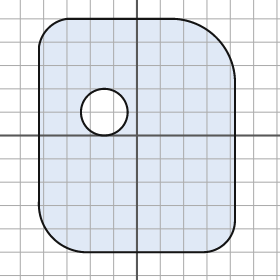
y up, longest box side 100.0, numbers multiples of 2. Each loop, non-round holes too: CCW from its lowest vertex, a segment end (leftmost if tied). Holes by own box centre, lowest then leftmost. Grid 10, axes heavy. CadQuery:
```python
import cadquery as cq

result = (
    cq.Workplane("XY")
    .moveTo(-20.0, -50.0)
    .lineTo(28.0, -50.0)
    .threePointArc((38.0, -46.0), (42.0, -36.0))
    .lineTo(42.0, 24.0)
    .threePointArc((34.0, 42.0), (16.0, 50.0))
    .lineTo(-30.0, 50.0)
    .threePointArc((-38.0, 46.0), (-42.0, 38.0))
    .lineTo(-42.0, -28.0)
    .threePointArc((-36.0, -44.0), (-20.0, -50.0))
    .close()
    .moveTo(-14.0, 10.0)
    .circle(10.0)
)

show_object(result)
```